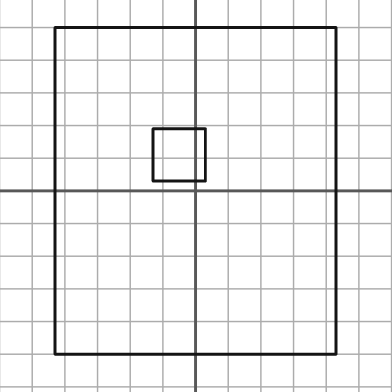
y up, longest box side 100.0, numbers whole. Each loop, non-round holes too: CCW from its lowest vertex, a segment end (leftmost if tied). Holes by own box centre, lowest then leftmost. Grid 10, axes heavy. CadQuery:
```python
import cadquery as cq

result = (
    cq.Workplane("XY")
    .moveTo(-43.0, -50.0)
    .lineTo(43.0, -50.0)
    .lineTo(43.0, 50.0)
    .lineTo(-43.0, 50.0)
    .close()
    .moveTo(-13.0, 3.0)
    .lineTo(3.0, 3.0)
    .lineTo(3.0, 19.0)
    .lineTo(-13.0, 19.0)
    .close()
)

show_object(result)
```